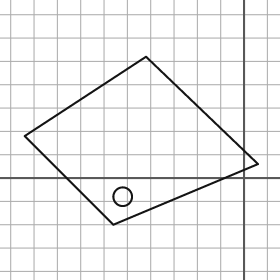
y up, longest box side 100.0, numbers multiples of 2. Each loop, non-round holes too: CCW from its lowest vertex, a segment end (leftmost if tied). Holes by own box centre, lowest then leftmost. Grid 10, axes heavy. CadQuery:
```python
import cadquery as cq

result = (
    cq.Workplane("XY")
    .moveTo(-56.0, -20.0)
    .lineTo(6.0, 6.0)
    .lineTo(-42.0, 52.0)
    .lineTo(-94.0, 18.0)
    .close()
    .moveTo(-52.0, -8.0)
    .circle(4.0)
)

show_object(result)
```